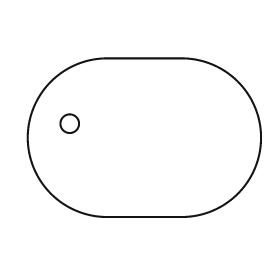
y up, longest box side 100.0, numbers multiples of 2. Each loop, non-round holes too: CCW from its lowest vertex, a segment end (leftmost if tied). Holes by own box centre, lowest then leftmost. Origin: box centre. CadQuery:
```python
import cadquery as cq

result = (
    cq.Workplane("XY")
    .moveTo(-16.0, -34.0)
    .lineTo(16.0, -34.0)
    .threePointArc((50.0, 0.0), (16.0, 34.0))
    .lineTo(-16.0, 34.0)
    .threePointArc((-50.0, 0.0), (-16.0, -34.0))
    .close()
    .moveTo(-32.0, 6.0)
    .circle(4.0)
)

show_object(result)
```